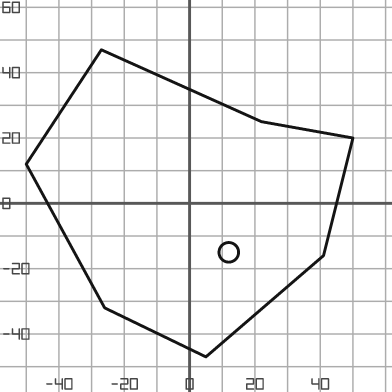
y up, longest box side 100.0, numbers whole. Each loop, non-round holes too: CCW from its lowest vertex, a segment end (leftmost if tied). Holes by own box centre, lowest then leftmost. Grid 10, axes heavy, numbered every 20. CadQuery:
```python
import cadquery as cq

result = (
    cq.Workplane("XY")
    .moveTo(5.0, -47.0)
    .lineTo(41.0, -16.0)
    .lineTo(50.0, 20.0)
    .lineTo(22.0, 25.0)
    .lineTo(-27.0, 47.0)
    .lineTo(-50.0, 12.0)
    .lineTo(-26.0, -32.0)
    .close()
    .moveTo(12.0, -15.0)
    .circle(3.0)
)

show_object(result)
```